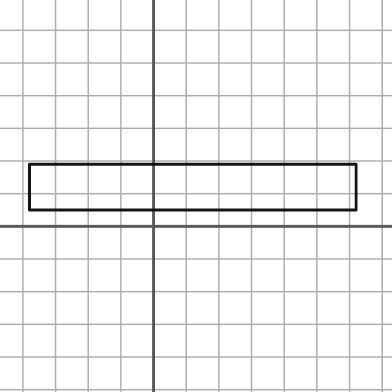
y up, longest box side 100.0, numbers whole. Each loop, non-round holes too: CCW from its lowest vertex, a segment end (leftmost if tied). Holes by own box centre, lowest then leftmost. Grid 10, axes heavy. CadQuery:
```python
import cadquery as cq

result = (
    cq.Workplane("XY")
    .moveTo(-38.0, 5.0)
    .lineTo(62.0, 5.0)
    .lineTo(62.0, 19.0)
    .lineTo(-38.0, 19.0)
    .close()
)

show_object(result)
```